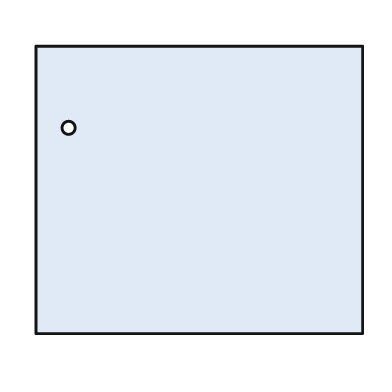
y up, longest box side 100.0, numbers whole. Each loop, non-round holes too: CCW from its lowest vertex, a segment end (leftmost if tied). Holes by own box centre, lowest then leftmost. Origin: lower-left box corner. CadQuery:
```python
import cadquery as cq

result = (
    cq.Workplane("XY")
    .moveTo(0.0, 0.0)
    .lineTo(100.0, 0.0)
    .lineTo(100.0, 88.0)
    .lineTo(0.0, 88.0)
    .close()
    .moveTo(10.0, 63.0)
    .circle(2.0)
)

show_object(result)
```